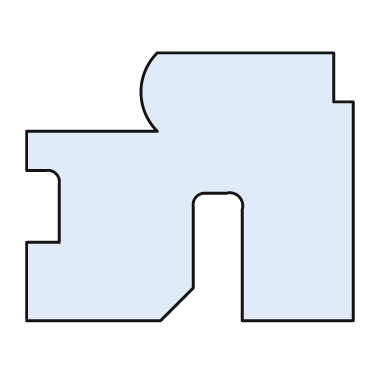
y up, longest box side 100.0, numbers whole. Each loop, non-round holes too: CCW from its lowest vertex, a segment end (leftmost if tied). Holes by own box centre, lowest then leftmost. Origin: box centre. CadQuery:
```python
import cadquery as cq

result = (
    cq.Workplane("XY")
    .moveTo(-50.0, -41.0)
    .lineTo(-9.0, -41.0)
    .lineTo(1.0, -31.0)
    .lineTo(1.0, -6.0)
    .threePointArc((2.0, -3.0), (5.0, -2.0))
    .lineTo(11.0, -2.0)
    .threePointArc((15.0, -3.0), (16.0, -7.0))
    .lineTo(16.0, -41.0)
    .lineTo(50.0, -41.0)
    .lineTo(50.0, 26.0)
    .lineTo(44.0, 26.0)
    .lineTo(44.0, 41.0)
    .lineTo(-10.0, 41.0)
    .threePointArc((-15.0, 29.0), (-10.0, 17.0))
    .lineTo(-50.0, 17.0)
    .lineTo(-50.0, 5.0)
    .lineTo(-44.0, 5.0)
    .threePointArc((-41.0, 4.0), (-40.0, 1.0))
    .lineTo(-40.0, -17.0)
    .lineTo(-50.0, -17.0)
    .close()
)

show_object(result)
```